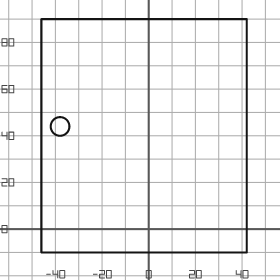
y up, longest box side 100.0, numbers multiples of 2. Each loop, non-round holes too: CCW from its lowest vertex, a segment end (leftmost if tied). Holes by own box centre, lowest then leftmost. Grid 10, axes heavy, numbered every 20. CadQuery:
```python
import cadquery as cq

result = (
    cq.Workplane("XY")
    .moveTo(-46.0, -10.0)
    .lineTo(42.0, -10.0)
    .lineTo(42.0, 90.0)
    .lineTo(-46.0, 90.0)
    .close()
    .moveTo(-38.0, 44.0)
    .circle(4.0)
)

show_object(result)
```